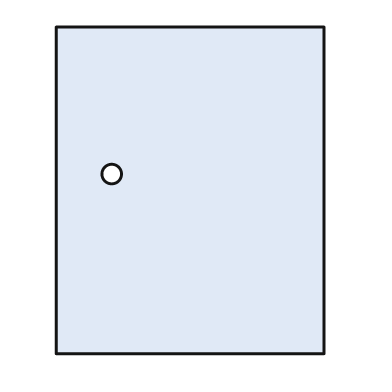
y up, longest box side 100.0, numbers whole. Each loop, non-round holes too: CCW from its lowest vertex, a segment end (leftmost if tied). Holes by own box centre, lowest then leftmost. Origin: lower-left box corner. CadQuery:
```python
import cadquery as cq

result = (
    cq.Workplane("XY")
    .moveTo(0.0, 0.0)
    .lineTo(82.0, 0.0)
    .lineTo(82.0, 100.0)
    .lineTo(0.0, 100.0)
    .close()
    .moveTo(17.0, 55.0)
    .circle(3.0)
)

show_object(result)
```